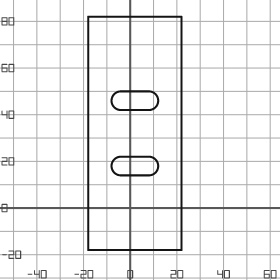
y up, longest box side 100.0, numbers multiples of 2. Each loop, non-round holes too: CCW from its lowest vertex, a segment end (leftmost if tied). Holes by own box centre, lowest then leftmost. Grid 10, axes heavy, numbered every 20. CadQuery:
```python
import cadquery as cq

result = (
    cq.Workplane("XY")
    .moveTo(-18.0, -18.0)
    .lineTo(22.0, -18.0)
    .lineTo(22.0, 82.0)
    .lineTo(-18.0, 82.0)
    .close()
    .moveTo(-4.0, 14.0)
    .lineTo(8.0, 14.0)
    .threePointArc((12.0, 18.0), (8.0, 22.0))
    .lineTo(-4.0, 22.0)
    .threePointArc((-8.0, 18.0), (-4.0, 14.0))
    .close()
    .moveTo(-4.0, 42.0)
    .lineTo(8.0, 42.0)
    .threePointArc((12.0, 46.0), (8.0, 50.0))
    .lineTo(-4.0, 50.0)
    .threePointArc((-8.0, 46.0), (-4.0, 42.0))
    .close()
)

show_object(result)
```